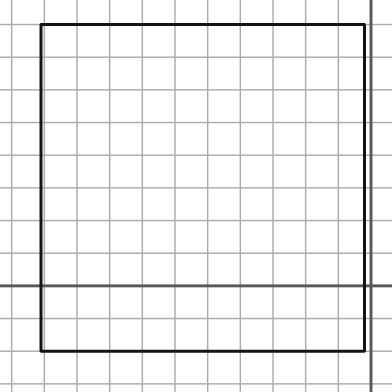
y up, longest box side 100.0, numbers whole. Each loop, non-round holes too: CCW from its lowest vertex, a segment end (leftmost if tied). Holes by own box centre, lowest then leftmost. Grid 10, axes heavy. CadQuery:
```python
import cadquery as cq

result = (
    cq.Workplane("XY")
    .moveTo(-101.0, -20.0)
    .lineTo(-2.0, -20.0)
    .lineTo(-2.0, 80.0)
    .lineTo(-101.0, 80.0)
    .close()
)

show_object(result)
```